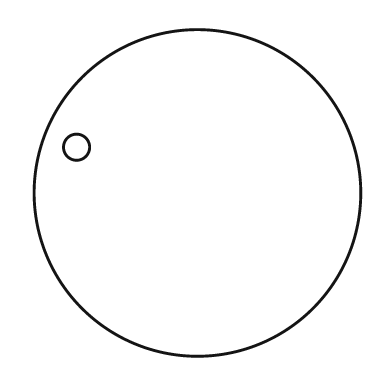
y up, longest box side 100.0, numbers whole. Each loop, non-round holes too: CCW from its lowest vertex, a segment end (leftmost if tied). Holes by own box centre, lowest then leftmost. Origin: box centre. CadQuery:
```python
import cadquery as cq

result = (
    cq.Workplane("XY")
    .moveTo(0.0, 0.0)
    .circle(50.0)
    .moveTo(-37.0, 14.0)
    .circle(4.0)
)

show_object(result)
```